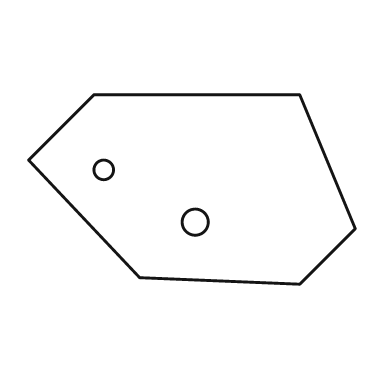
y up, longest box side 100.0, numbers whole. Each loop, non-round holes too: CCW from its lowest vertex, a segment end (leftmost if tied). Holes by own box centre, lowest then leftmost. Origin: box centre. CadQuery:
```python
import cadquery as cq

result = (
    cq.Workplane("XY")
    .moveTo(33.0, -29.0)
    .lineTo(50.0, -12.0)
    .lineTo(33.0, 29.0)
    .lineTo(-30.0, 29.0)
    .lineTo(-50.0, 9.0)
    .lineTo(-16.0, -27.0)
    .close()
    .moveTo(1.0, -10.0)
    .circle(4.0)
    .moveTo(-27.0, 6.0)
    .circle(3.0)
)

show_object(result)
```